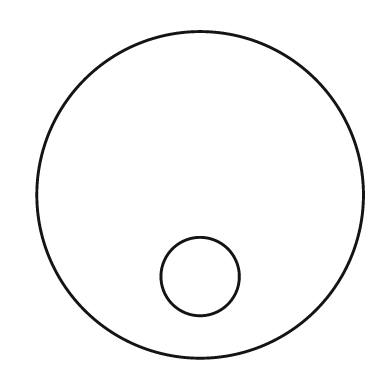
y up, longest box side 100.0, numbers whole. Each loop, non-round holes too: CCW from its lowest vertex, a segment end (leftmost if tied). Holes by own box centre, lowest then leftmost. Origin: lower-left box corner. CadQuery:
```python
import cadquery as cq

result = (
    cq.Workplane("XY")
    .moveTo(50.0, 50.0)
    .circle(50.0)
    .moveTo(50.0, 25.0)
    .circle(12.0)
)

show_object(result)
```